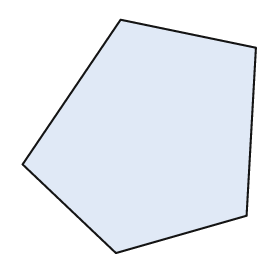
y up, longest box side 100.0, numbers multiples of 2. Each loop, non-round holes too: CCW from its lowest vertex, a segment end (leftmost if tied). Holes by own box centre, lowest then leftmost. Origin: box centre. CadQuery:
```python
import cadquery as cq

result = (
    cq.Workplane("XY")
    .moveTo(-10.0, -50.0)
    .lineTo(46.0, -34.0)
    .lineTo(50.0, 38.0)
    .lineTo(-8.0, 50.0)
    .lineTo(-50.0, -12.0)
    .close()
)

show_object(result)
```